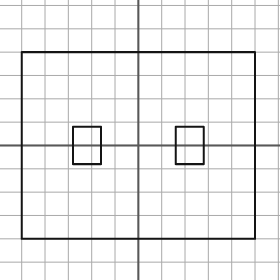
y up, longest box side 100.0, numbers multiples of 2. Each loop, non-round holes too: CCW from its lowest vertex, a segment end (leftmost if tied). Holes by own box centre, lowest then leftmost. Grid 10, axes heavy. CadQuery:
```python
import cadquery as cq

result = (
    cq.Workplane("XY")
    .moveTo(-50.0, -40.0)
    .lineTo(50.0, -40.0)
    .lineTo(50.0, 40.0)
    .lineTo(-50.0, 40.0)
    .close()
    .moveTo(-28.0, -8.0)
    .lineTo(-16.0, -8.0)
    .lineTo(-16.0, 8.0)
    .lineTo(-28.0, 8.0)
    .close()
    .moveTo(16.0, -8.0)
    .lineTo(28.0, -8.0)
    .lineTo(28.0, 8.0)
    .lineTo(16.0, 8.0)
    .close()
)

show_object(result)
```